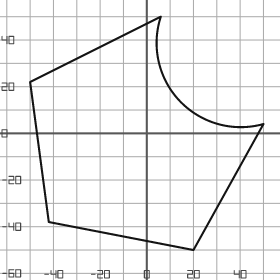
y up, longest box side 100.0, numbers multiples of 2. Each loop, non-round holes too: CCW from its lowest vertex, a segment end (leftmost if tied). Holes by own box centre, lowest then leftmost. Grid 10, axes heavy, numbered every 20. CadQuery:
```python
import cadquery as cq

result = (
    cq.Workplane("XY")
    .moveTo(20.0, -50.0)
    .lineTo(50.0, 4.0)
    .threePointArc((14.0, 14.0), (6.0, 50.0))
    .lineTo(-50.0, 22.0)
    .lineTo(-42.0, -38.0)
    .close()
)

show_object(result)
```